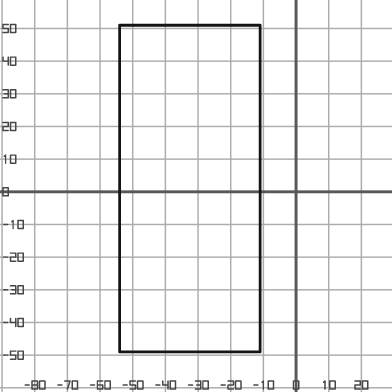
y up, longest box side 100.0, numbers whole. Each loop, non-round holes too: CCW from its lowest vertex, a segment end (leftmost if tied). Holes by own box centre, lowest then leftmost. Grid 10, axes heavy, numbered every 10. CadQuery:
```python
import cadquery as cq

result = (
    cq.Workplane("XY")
    .moveTo(-54.0, -49.0)
    .lineTo(-11.0, -49.0)
    .lineTo(-11.0, 51.0)
    .lineTo(-54.0, 51.0)
    .close()
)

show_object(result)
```